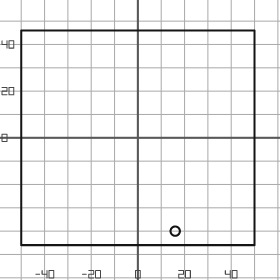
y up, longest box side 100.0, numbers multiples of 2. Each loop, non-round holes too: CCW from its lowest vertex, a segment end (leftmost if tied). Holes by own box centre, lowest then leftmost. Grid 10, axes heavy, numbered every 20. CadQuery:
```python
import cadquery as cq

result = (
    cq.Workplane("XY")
    .moveTo(-50.0, -46.0)
    .lineTo(50.0, -46.0)
    .lineTo(50.0, 46.0)
    .lineTo(-50.0, 46.0)
    .close()
    .moveTo(16.0, -40.0)
    .circle(2.0)
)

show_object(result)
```